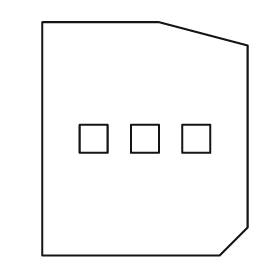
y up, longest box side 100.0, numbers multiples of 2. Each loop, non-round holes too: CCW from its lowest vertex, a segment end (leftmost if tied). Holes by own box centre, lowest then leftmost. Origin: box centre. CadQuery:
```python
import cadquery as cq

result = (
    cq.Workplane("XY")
    .moveTo(-44.0, -50.0)
    .lineTo(32.0, -50.0)
    .lineTo(44.0, -38.0)
    .lineTo(44.0, 40.0)
    .lineTo(6.0, 50.0)
    .lineTo(-44.0, 50.0)
    .close()
    .moveTo(-28.0, -6.0)
    .lineTo(-16.0, -6.0)
    .lineTo(-16.0, 6.0)
    .lineTo(-28.0, 6.0)
    .close()
    .moveTo(-6.0, -6.0)
    .lineTo(6.0, -6.0)
    .lineTo(6.0, 6.0)
    .lineTo(-6.0, 6.0)
    .close()
    .moveTo(16.0, -6.0)
    .lineTo(28.0, -6.0)
    .lineTo(28.0, 6.0)
    .lineTo(16.0, 6.0)
    .close()
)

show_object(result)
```